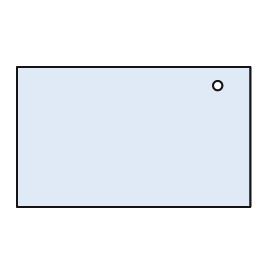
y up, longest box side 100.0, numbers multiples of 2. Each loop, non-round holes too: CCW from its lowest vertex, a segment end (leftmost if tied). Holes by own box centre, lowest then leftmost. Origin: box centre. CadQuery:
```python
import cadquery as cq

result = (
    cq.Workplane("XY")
    .moveTo(-50.0, -30.0)
    .lineTo(50.0, -30.0)
    .lineTo(50.0, 30.0)
    .lineTo(-50.0, 30.0)
    .close()
    .moveTo(36.0, 22.0)
    .circle(2.0)
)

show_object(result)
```